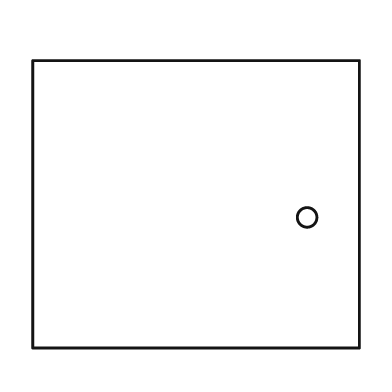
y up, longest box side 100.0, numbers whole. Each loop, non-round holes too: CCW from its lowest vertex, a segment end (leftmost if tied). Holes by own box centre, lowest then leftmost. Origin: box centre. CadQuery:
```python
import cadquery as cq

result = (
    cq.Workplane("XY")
    .moveTo(-50.0, -44.0)
    .lineTo(50.0, -44.0)
    .lineTo(50.0, 44.0)
    .lineTo(-50.0, 44.0)
    .close()
    .moveTo(34.0, -4.0)
    .circle(3.0)
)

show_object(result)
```